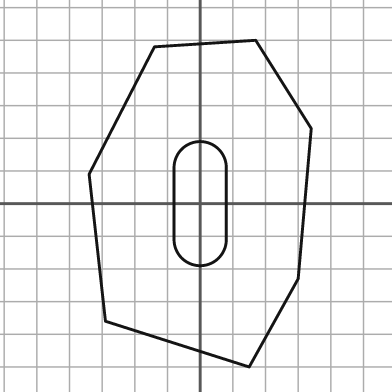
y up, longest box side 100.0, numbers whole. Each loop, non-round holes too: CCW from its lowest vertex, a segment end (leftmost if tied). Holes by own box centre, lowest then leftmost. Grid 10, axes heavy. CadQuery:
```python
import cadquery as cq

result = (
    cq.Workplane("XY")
    .moveTo(15.0, -50.0)
    .lineTo(30.0, -23.0)
    .lineTo(34.0, 23.0)
    .lineTo(17.0, 50.0)
    .lineTo(-14.0, 48.0)
    .lineTo(-34.0, 9.0)
    .lineTo(-29.0, -36.0)
    .close()
    .moveTo(-8.0, -11.0)
    .threePointArc((0.0, -19.0), (8.0, -11.0))
    .lineTo(8.0, 11.0)
    .threePointArc((0.0, 19.0), (-8.0, 11.0))
    .close()
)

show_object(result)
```